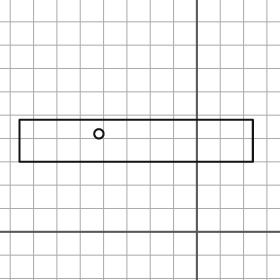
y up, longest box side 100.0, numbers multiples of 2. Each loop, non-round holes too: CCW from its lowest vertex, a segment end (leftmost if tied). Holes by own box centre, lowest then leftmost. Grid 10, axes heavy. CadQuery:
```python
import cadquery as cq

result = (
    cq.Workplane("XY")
    .moveTo(-76.0, 30.0)
    .lineTo(24.0, 30.0)
    .lineTo(24.0, 48.0)
    .lineTo(-76.0, 48.0)
    .close()
    .moveTo(-42.0, 42.0)
    .circle(2.0)
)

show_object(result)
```